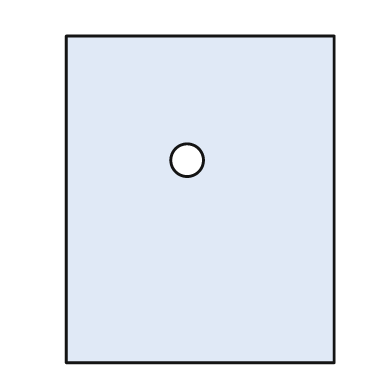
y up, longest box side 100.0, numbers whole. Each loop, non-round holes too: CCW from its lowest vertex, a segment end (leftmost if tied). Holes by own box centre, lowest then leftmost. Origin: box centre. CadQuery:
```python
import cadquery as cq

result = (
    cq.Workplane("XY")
    .moveTo(-41.0, -50.0)
    .lineTo(41.0, -50.0)
    .lineTo(41.0, 50.0)
    .lineTo(-41.0, 50.0)
    .close()
    .moveTo(-4.0, 12.0)
    .circle(5.0)
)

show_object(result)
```